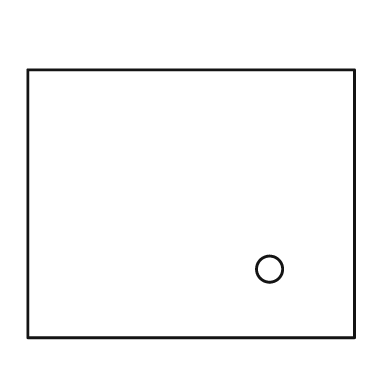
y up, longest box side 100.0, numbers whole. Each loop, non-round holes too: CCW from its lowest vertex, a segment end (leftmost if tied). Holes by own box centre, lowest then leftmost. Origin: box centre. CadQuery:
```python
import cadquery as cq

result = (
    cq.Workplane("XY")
    .moveTo(-50.0, -41.0)
    .lineTo(50.0, -41.0)
    .lineTo(50.0, 41.0)
    .lineTo(-50.0, 41.0)
    .close()
    .moveTo(24.0, -20.0)
    .circle(4.0)
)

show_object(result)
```